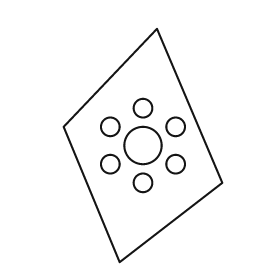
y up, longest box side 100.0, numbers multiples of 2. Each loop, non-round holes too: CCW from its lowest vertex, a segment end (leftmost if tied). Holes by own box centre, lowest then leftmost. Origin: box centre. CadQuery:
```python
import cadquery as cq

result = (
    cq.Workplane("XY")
    .moveTo(-10.0, -50.0)
    .lineTo(34.0, -16.0)
    .lineTo(6.0, 50.0)
    .lineTo(-34.0, 8.0)
    .close()
    .moveTo(0.0, -16.0)
    .circle(4.0)
    .moveTo(-14.0, -8.0)
    .circle(4.0)
    .moveTo(14.0, -8.0)
    .circle(4.0)
    .moveTo(0.0, 0.0)
    .circle(8.0)
    .moveTo(-14.0, 8.0)
    .circle(4.0)
    .moveTo(14.0, 8.0)
    .circle(4.0)
    .moveTo(0.0, 16.0)
    .circle(4.0)
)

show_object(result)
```